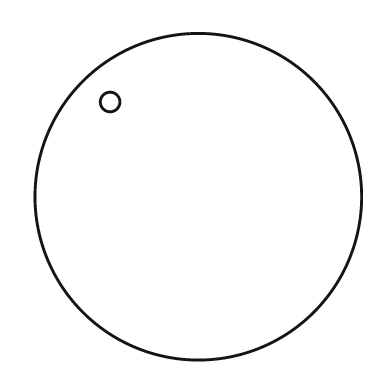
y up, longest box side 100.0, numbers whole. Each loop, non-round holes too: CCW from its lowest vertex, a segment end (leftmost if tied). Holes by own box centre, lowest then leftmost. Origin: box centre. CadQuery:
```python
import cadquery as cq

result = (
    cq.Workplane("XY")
    .moveTo(0.0, 0.0)
    .circle(50.0)
    .moveTo(-27.0, 29.0)
    .circle(3.0)
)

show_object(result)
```